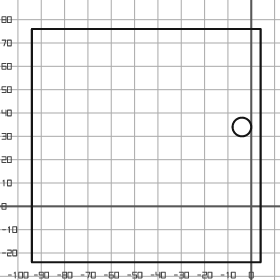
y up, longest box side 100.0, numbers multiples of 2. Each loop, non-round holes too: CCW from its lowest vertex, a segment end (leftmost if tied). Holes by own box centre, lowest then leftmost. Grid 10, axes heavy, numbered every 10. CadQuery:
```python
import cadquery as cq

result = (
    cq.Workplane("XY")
    .moveTo(-94.0, -24.0)
    .lineTo(4.0, -24.0)
    .lineTo(4.0, 76.0)
    .lineTo(-94.0, 76.0)
    .close()
    .moveTo(-4.0, 34.0)
    .circle(4.0)
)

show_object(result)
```